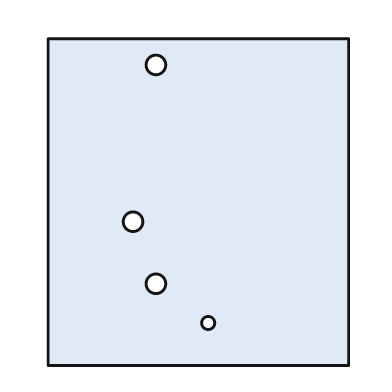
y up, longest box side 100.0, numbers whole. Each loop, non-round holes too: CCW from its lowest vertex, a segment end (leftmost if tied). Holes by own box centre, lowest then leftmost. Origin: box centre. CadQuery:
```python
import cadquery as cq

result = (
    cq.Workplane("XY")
    .moveTo(-46.0, -50.0)
    .lineTo(46.0, -50.0)
    .lineTo(46.0, 50.0)
    .lineTo(-46.0, 50.0)
    .close()
    .moveTo(3.0, -37.0)
    .circle(2.0)
    .moveTo(-13.0, -25.0)
    .circle(3.0)
    .moveTo(-20.0, -6.0)
    .circle(3.0)
    .moveTo(-13.0, 42.0)
    .circle(3.0)
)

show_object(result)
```